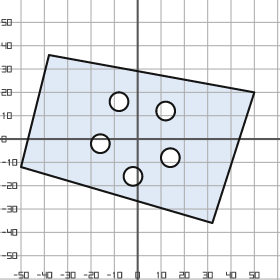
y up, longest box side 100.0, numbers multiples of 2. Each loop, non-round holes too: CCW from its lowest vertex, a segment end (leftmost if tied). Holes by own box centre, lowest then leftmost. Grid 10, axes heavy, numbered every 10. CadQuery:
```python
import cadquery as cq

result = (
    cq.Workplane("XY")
    .moveTo(32.0, -36.0)
    .lineTo(50.0, 20.0)
    .lineTo(-38.0, 36.0)
    .lineTo(-50.0, -12.0)
    .close()
    .moveTo(-2.0, -16.0)
    .circle(4.0)
    .moveTo(14.0, -8.0)
    .circle(4.0)
    .moveTo(-16.0, -2.0)
    .circle(4.0)
    .moveTo(12.0, 12.0)
    .circle(4.0)
    .moveTo(-8.0, 16.0)
    .circle(4.0)
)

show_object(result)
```